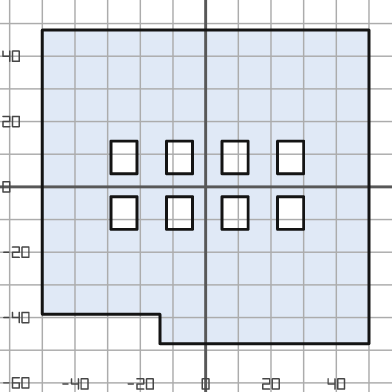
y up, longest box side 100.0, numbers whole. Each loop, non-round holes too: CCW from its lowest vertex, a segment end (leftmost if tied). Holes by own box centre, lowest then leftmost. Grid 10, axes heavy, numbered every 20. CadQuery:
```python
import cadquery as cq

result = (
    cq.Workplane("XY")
    .moveTo(-14.0, -48.0)
    .lineTo(50.0, -48.0)
    .lineTo(50.0, 48.0)
    .lineTo(-50.0, 48.0)
    .lineTo(-50.0, -39.0)
    .lineTo(-14.0, -39.0)
    .close()
    .moveTo(-29.0, -13.0)
    .lineTo(-21.0, -13.0)
    .lineTo(-21.0, -3.0)
    .lineTo(-29.0, -3.0)
    .close()
    .moveTo(-12.0, -13.0)
    .lineTo(-4.0, -13.0)
    .lineTo(-4.0, -3.0)
    .lineTo(-12.0, -3.0)
    .close()
    .moveTo(5.0, -13.0)
    .lineTo(13.0, -13.0)
    .lineTo(13.0, -3.0)
    .lineTo(5.0, -3.0)
    .close()
    .moveTo(22.0, -13.0)
    .lineTo(30.0, -13.0)
    .lineTo(30.0, -3.0)
    .lineTo(22.0, -3.0)
    .close()
    .moveTo(-29.0, 4.0)
    .lineTo(-21.0, 4.0)
    .lineTo(-21.0, 14.0)
    .lineTo(-29.0, 14.0)
    .close()
    .moveTo(-12.0, 4.0)
    .lineTo(-4.0, 4.0)
    .lineTo(-4.0, 14.0)
    .lineTo(-12.0, 14.0)
    .close()
    .moveTo(5.0, 4.0)
    .lineTo(13.0, 4.0)
    .lineTo(13.0, 14.0)
    .lineTo(5.0, 14.0)
    .close()
    .moveTo(22.0, 4.0)
    .lineTo(30.0, 4.0)
    .lineTo(30.0, 14.0)
    .lineTo(22.0, 14.0)
    .close()
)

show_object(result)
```